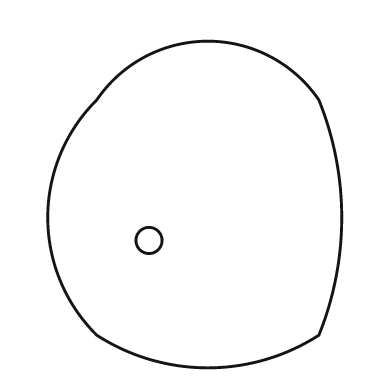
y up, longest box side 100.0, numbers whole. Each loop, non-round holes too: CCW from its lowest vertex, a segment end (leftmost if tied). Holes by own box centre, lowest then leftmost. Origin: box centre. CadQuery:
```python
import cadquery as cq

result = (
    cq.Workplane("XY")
    .moveTo(-30.0, -40.0)
    .threePointArc((4.0, -50.0), (38.0, -40.0))
    .threePointArc((45.0, -4.0), (38.0, 32.0))
    .threePointArc((4.0, 50.0), (-30.0, 32.0))
    .threePointArc((-45.0, -4.0), (-30.0, -40.0))
    .close()
    .moveTo(-14.0, -11.0)
    .circle(4.0)
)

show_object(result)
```